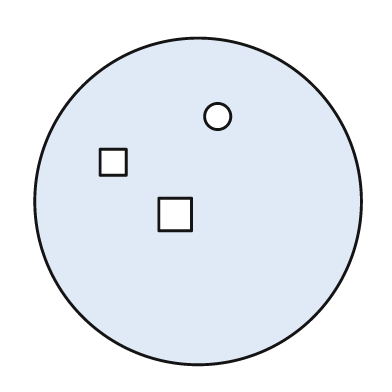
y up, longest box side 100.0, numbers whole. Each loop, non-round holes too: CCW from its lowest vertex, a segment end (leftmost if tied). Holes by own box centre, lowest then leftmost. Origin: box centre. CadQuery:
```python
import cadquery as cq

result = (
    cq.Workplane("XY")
    .moveTo(0.0, 0.0)
    .circle(50.0)
    .moveTo(-12.0, -9.0)
    .lineTo(-2.0, -9.0)
    .lineTo(-2.0, 1.0)
    .lineTo(-12.0, 1.0)
    .close()
    .moveTo(-30.0, 8.0)
    .lineTo(-22.0, 8.0)
    .lineTo(-22.0, 16.0)
    .lineTo(-30.0, 16.0)
    .close()
    .moveTo(6.0, 26.0)
    .circle(4.0)
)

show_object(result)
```